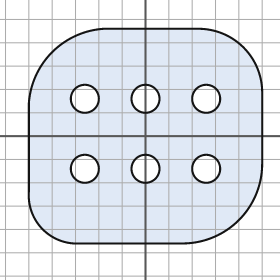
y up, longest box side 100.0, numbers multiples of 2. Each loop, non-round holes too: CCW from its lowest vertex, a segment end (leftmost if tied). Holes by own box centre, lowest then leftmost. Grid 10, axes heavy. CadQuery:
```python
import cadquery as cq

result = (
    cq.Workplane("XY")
    .moveTo(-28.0, -46.0)
    .lineTo(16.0, -46.0)
    .threePointArc((40.0, -36.0), (50.0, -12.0))
    .lineTo(50.0, 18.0)
    .threePointArc((42.0, 38.0), (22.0, 46.0))
    .lineTo(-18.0, 46.0)
    .threePointArc((-40.0, 36.0), (-50.0, 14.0))
    .lineTo(-50.0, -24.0)
    .threePointArc((-44.0, -40.0), (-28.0, -46.0))
    .close()
    .moveTo(-26.0, -14.0)
    .circle(6.0)
    .moveTo(0.0, -14.0)
    .circle(6.0)
    .moveTo(26.0, -14.0)
    .circle(6.0)
    .moveTo(-26.0, 16.0)
    .circle(6.0)
    .moveTo(0.0, 16.0)
    .circle(6.0)
    .moveTo(26.0, 16.0)
    .circle(6.0)
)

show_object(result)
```